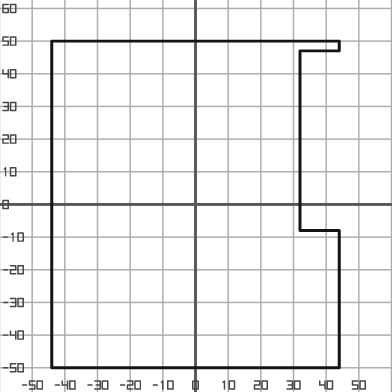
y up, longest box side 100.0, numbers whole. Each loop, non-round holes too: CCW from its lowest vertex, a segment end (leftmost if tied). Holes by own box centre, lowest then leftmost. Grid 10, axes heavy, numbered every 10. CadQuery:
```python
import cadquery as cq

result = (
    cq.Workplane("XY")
    .moveTo(-44.0, -50.0)
    .lineTo(44.0, -50.0)
    .lineTo(44.0, -8.0)
    .lineTo(32.0, -8.0)
    .lineTo(32.0, 47.0)
    .lineTo(44.0, 47.0)
    .lineTo(44.0, 50.0)
    .lineTo(-44.0, 50.0)
    .close()
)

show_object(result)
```